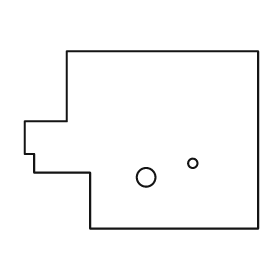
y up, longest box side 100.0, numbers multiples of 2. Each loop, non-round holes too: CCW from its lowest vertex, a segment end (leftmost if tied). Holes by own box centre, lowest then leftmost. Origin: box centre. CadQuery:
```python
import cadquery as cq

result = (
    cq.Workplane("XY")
    .moveTo(-22.0, -38.0)
    .lineTo(50.0, -38.0)
    .lineTo(50.0, 38.0)
    .lineTo(-32.0, 38.0)
    .lineTo(-32.0, 8.0)
    .lineTo(-50.0, 8.0)
    .lineTo(-50.0, -6.0)
    .lineTo(-46.0, -6.0)
    .lineTo(-46.0, -14.0)
    .lineTo(-22.0, -14.0)
    .close()
    .moveTo(2.0, -16.0)
    .circle(4.0)
    .moveTo(22.0, -10.0)
    .circle(2.0)
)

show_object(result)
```